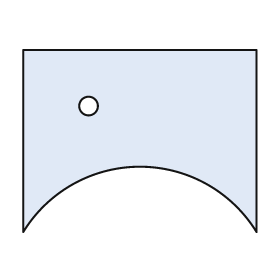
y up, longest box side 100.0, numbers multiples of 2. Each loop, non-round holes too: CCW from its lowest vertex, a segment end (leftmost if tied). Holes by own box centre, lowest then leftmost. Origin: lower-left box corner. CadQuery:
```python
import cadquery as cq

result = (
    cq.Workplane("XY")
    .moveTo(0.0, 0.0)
    .threePointArc((50.0, 28.0), (100.0, 0.0))
    .lineTo(100.0, 78.0)
    .lineTo(0.0, 78.0)
    .close()
    .moveTo(28.0, 54.0)
    .circle(4.0)
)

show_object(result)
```